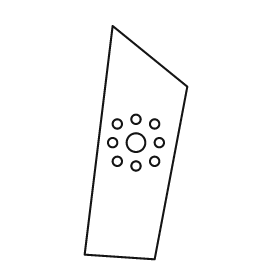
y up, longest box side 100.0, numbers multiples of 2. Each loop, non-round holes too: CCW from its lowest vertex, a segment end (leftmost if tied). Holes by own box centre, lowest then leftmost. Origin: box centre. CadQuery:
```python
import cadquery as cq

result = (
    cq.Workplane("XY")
    .moveTo(8.0, -50.0)
    .lineTo(22.0, 24.0)
    .lineTo(-10.0, 50.0)
    .lineTo(-22.0, -48.0)
    .close()
    .moveTo(0.0, -10.0)
    .circle(2.0)
    .moveTo(-8.0, -8.0)
    .circle(2.0)
    .moveTo(8.0, -8.0)
    .circle(2.0)
    .moveTo(-10.0, 0.0)
    .circle(2.0)
    .moveTo(0.0, 0.0)
    .circle(4.0)
    .moveTo(10.0, 0.0)
    .circle(2.0)
    .moveTo(-8.0, 8.0)
    .circle(2.0)
    .moveTo(8.0, 8.0)
    .circle(2.0)
    .moveTo(0.0, 10.0)
    .circle(2.0)
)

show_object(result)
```